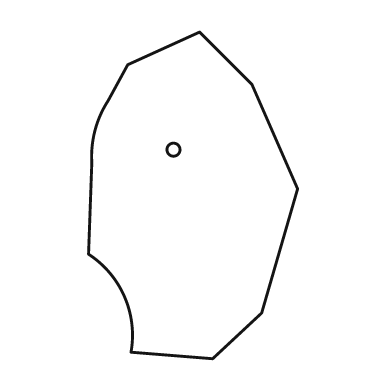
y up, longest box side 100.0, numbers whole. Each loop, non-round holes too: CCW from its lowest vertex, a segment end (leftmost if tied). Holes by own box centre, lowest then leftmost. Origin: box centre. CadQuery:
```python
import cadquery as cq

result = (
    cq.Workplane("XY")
    .moveTo(6.0, -50.0)
    .lineTo(21.0, -36.0)
    .lineTo(32.0, 2.0)
    .lineTo(18.0, 34.0)
    .lineTo(2.0, 50.0)
    .lineTo(-20.0, 40.0)
    .lineTo(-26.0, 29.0)
    .threePointArc((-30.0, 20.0), (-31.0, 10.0))
    .lineTo(-32.0, -18.0)
    .threePointArc((-21.0, -31.0), (-19.0, -48.0))
    .close()
    .moveTo(-6.0, 14.0)
    .circle(2.0)
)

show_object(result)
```